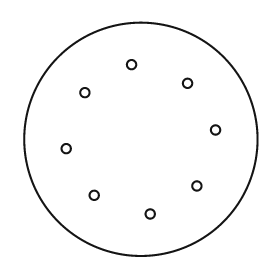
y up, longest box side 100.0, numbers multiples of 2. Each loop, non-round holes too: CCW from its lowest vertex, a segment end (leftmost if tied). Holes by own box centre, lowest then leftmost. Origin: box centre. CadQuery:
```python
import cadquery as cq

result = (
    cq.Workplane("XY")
    .moveTo(0.0, 0.0)
    .circle(50.0)
    .moveTo(4.0, -32.0)
    .circle(2.0)
    .moveTo(-20.0, -24.0)
    .circle(2.0)
    .moveTo(24.0, -20.0)
    .circle(2.0)
    .moveTo(-32.0, -4.0)
    .circle(2.0)
    .moveTo(32.0, 4.0)
    .circle(2.0)
    .moveTo(-24.0, 20.0)
    .circle(2.0)
    .moveTo(20.0, 24.0)
    .circle(2.0)
    .moveTo(-4.0, 32.0)
    .circle(2.0)
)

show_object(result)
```